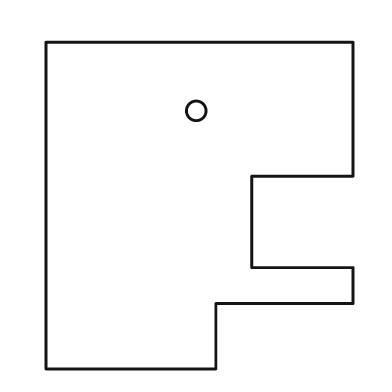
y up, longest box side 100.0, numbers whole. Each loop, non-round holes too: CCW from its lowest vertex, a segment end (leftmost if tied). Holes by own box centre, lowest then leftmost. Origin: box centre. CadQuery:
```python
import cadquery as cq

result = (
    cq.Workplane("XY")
    .moveTo(-47.0, -50.0)
    .lineTo(5.0, -50.0)
    .lineTo(5.0, -30.0)
    .lineTo(47.0, -30.0)
    .lineTo(47.0, -19.0)
    .lineTo(16.0, -19.0)
    .lineTo(16.0, 9.0)
    .lineTo(47.0, 9.0)
    .lineTo(47.0, 50.0)
    .lineTo(-47.0, 50.0)
    .close()
    .moveTo(-1.0, 29.0)
    .circle(3.0)
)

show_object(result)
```